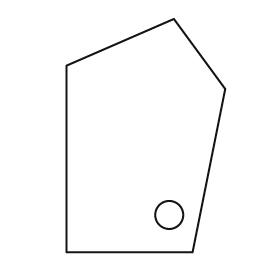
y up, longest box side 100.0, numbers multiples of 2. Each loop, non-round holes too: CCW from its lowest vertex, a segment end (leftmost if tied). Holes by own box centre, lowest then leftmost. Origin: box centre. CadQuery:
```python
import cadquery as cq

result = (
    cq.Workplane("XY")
    .moveTo(-34.0, -50.0)
    .lineTo(20.0, -50.0)
    .lineTo(34.0, 20.0)
    .lineTo(12.0, 50.0)
    .lineTo(-34.0, 30.0)
    .close()
    .moveTo(10.0, -34.0)
    .circle(6.0)
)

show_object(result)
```